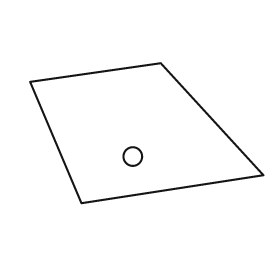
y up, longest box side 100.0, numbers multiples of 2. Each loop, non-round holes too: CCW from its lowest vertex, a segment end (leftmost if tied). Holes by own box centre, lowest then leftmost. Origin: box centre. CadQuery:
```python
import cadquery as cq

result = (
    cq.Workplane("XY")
    .moveTo(-28.0, -30.0)
    .lineTo(50.0, -18.0)
    .lineTo(6.0, 30.0)
    .lineTo(-50.0, 22.0)
    .close()
    .moveTo(-6.0, -10.0)
    .circle(4.0)
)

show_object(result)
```